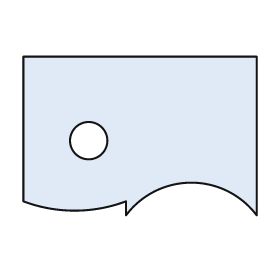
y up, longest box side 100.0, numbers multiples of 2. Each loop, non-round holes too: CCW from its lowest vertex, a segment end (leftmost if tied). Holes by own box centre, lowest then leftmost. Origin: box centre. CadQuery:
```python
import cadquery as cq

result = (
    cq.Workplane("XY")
    .moveTo(-6.0, -34.0)
    .threePointArc((22.0, -20.0), (50.0, -34.0))
    .lineTo(50.0, 34.0)
    .lineTo(-50.0, 34.0)
    .lineTo(-50.0, -28.0)
    .threePointArc((-28.0, -32.0), (-6.0, -28.0))
    .close()
    .moveTo(-22.0, -2.0)
    .circle(8.0)
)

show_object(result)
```